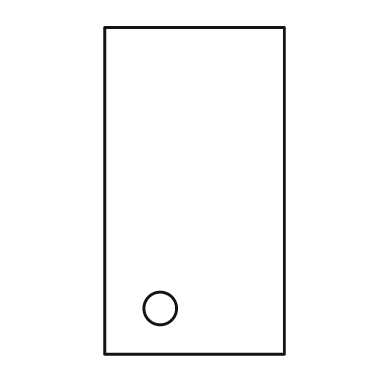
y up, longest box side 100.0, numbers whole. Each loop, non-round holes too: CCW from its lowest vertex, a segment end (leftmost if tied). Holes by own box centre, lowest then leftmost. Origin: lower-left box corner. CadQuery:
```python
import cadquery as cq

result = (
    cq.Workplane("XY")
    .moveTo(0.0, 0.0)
    .lineTo(55.0, 0.0)
    .lineTo(55.0, 100.0)
    .lineTo(0.0, 100.0)
    .close()
    .moveTo(17.0, 14.0)
    .circle(5.0)
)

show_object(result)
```